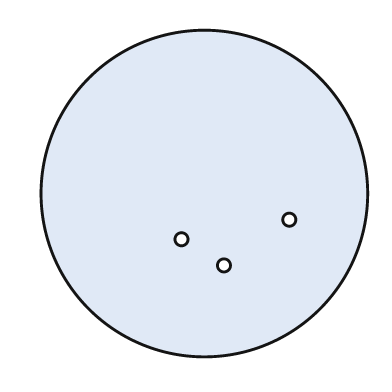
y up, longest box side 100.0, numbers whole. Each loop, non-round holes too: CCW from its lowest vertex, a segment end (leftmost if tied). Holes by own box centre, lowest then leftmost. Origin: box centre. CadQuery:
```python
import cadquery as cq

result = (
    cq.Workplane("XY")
    .moveTo(0.0, 0.0)
    .circle(50.0)
    .moveTo(6.0, -22.0)
    .circle(2.0)
    .moveTo(-7.0, -14.0)
    .circle(2.0)
    .moveTo(26.0, -8.0)
    .circle(2.0)
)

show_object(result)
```